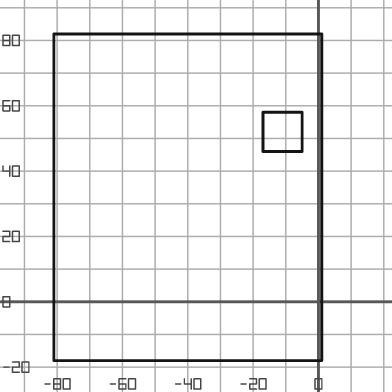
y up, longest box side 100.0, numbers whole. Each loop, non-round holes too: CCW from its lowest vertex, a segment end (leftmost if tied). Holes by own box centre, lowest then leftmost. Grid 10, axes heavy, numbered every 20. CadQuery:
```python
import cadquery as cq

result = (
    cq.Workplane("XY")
    .moveTo(-81.0, -18.0)
    .lineTo(1.0, -18.0)
    .lineTo(1.0, 82.0)
    .lineTo(-81.0, 82.0)
    .close()
    .moveTo(-17.0, 46.0)
    .lineTo(-5.0, 46.0)
    .lineTo(-5.0, 58.0)
    .lineTo(-17.0, 58.0)
    .close()
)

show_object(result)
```